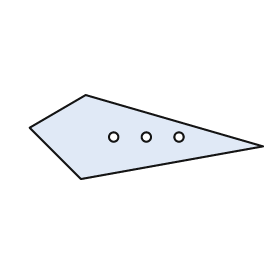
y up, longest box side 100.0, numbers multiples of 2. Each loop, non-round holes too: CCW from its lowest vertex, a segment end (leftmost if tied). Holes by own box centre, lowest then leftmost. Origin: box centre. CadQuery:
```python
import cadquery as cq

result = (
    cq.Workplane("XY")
    .moveTo(-28.0, -18.0)
    .lineTo(50.0, -4.0)
    .lineTo(-26.0, 18.0)
    .lineTo(-50.0, 4.0)
    .close()
    .moveTo(-14.0, 0.0)
    .circle(2.0)
    .moveTo(0.0, 0.0)
    .circle(2.0)
    .moveTo(14.0, 0.0)
    .circle(2.0)
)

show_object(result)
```